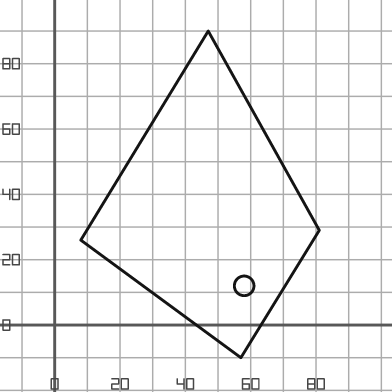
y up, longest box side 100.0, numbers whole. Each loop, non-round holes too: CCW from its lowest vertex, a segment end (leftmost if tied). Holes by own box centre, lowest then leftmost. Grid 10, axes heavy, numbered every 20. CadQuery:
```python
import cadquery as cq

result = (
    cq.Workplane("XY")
    .moveTo(57.0, -10.0)
    .lineTo(81.0, 29.0)
    .lineTo(47.0, 90.0)
    .lineTo(8.0, 26.0)
    .close()
    .moveTo(58.0, 12.0)
    .circle(3.0)
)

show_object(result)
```